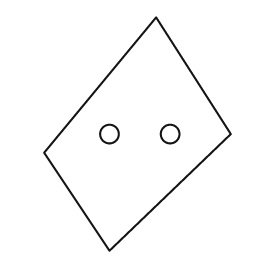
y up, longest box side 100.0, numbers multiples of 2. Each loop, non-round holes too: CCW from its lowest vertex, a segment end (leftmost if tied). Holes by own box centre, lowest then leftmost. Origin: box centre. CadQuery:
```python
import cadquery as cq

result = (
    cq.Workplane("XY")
    .moveTo(-12.0, -50.0)
    .lineTo(40.0, 0.0)
    .lineTo(8.0, 50.0)
    .lineTo(-40.0, -8.0)
    .close()
    .moveTo(-12.0, 0.0)
    .circle(4.0)
    .moveTo(14.0, 0.0)
    .circle(4.0)
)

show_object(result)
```